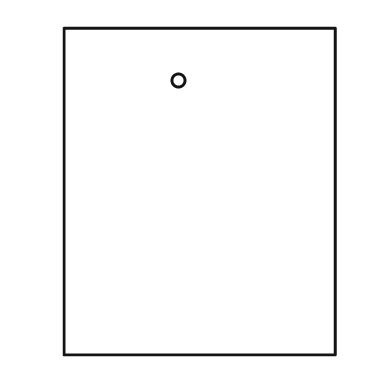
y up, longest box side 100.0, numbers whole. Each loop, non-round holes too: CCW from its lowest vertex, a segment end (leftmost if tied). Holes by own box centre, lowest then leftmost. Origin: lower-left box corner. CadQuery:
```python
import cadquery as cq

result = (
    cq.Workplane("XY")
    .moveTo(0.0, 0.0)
    .lineTo(83.0, 0.0)
    .lineTo(83.0, 100.0)
    .lineTo(0.0, 100.0)
    .close()
    .moveTo(35.0, 84.0)
    .circle(2.0)
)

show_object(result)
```